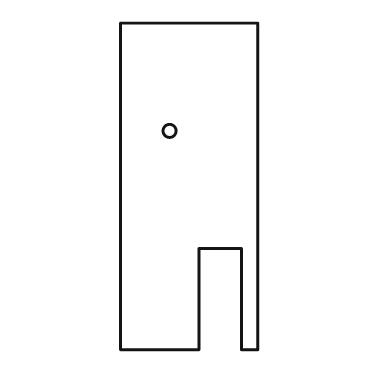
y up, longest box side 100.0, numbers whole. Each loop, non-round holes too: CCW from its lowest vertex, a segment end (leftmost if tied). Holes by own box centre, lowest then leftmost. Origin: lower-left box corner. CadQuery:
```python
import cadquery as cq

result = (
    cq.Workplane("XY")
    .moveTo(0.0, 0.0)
    .lineTo(24.0, 0.0)
    .lineTo(24.0, 31.0)
    .lineTo(37.0, 31.0)
    .lineTo(37.0, 0.0)
    .lineTo(42.0, 0.0)
    .lineTo(42.0, 100.0)
    .lineTo(0.0, 100.0)
    .close()
    .moveTo(15.0, 67.0)
    .circle(2.0)
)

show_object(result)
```